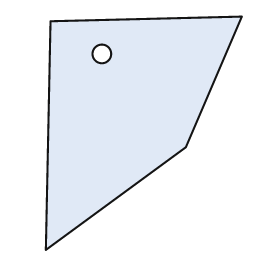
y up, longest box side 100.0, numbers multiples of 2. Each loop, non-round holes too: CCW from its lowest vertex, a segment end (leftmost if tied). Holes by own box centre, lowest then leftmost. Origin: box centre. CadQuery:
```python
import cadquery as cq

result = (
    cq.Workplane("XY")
    .moveTo(-42.0, -50.0)
    .lineTo(18.0, -6.0)
    .lineTo(42.0, 50.0)
    .lineTo(-40.0, 48.0)
    .close()
    .moveTo(-18.0, 34.0)
    .circle(4.0)
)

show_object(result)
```